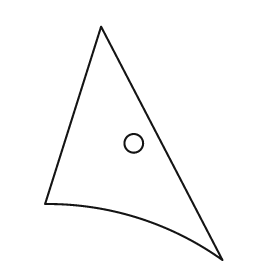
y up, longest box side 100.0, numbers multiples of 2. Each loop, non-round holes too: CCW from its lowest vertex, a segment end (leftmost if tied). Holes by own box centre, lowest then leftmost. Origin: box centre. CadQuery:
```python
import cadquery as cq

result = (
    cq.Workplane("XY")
    .moveTo(38.0, -50.0)
    .lineTo(-14.0, 50.0)
    .lineTo(-38.0, -26.0)
    .threePointArc((2.0, -32.0), (38.0, -50.0))
    .close()
    .moveTo(0.0, 0.0)
    .circle(4.0)
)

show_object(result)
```